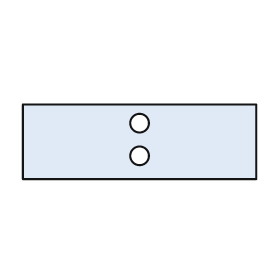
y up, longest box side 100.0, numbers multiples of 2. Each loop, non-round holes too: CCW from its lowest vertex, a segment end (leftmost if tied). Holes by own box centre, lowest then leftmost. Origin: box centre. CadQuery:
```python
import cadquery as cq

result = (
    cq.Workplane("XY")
    .moveTo(-50.0, -16.0)
    .lineTo(50.0, -16.0)
    .lineTo(50.0, 16.0)
    .lineTo(-50.0, 16.0)
    .close()
    .moveTo(0.0, -6.0)
    .circle(4.0)
    .moveTo(0.0, 8.0)
    .circle(4.0)
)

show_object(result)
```